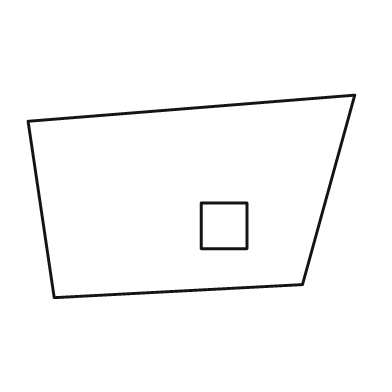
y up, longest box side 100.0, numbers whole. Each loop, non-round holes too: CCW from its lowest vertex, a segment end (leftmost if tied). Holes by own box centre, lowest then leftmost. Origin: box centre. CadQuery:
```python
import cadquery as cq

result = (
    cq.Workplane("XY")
    .moveTo(-42.0, -31.0)
    .lineTo(34.0, -27.0)
    .lineTo(50.0, 31.0)
    .lineTo(-50.0, 23.0)
    .close()
    .moveTo(3.0, -16.0)
    .lineTo(17.0, -16.0)
    .lineTo(17.0, -2.0)
    .lineTo(3.0, -2.0)
    .close()
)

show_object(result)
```